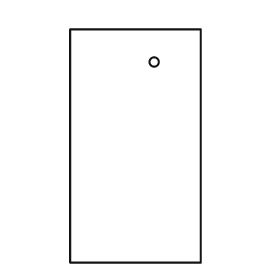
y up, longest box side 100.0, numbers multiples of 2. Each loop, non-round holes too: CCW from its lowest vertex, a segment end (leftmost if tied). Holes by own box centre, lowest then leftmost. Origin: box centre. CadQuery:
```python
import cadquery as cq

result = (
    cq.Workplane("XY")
    .moveTo(-28.0, -50.0)
    .lineTo(28.0, -50.0)
    .lineTo(28.0, 50.0)
    .lineTo(-28.0, 50.0)
    .close()
    .moveTo(8.0, 36.0)
    .circle(2.0)
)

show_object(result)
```